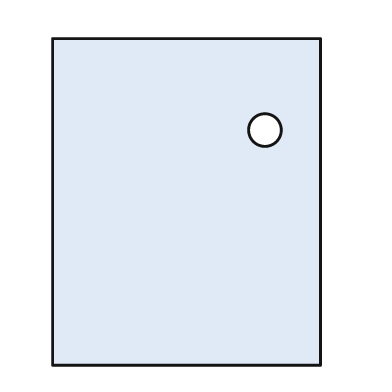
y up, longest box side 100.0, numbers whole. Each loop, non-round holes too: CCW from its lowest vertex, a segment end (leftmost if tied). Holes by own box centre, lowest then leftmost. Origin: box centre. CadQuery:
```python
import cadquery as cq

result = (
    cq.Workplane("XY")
    .moveTo(-41.0, -50.0)
    .lineTo(41.0, -50.0)
    .lineTo(41.0, 50.0)
    .lineTo(-41.0, 50.0)
    .close()
    .moveTo(24.0, 22.0)
    .circle(5.0)
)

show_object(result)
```